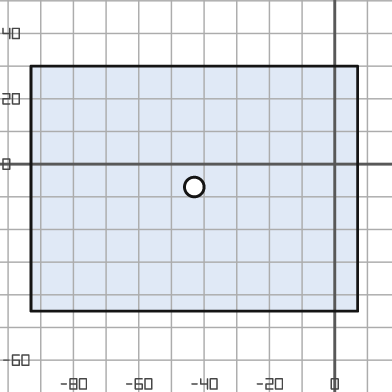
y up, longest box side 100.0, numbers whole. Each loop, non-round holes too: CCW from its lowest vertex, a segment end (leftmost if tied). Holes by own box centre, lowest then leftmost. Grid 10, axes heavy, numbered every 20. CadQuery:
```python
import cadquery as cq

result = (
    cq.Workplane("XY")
    .moveTo(-93.0, -45.0)
    .lineTo(7.0, -45.0)
    .lineTo(7.0, 30.0)
    .lineTo(-93.0, 30.0)
    .close()
    .moveTo(-43.0, -7.0)
    .circle(3.0)
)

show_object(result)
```